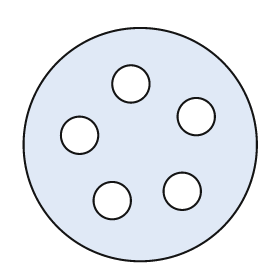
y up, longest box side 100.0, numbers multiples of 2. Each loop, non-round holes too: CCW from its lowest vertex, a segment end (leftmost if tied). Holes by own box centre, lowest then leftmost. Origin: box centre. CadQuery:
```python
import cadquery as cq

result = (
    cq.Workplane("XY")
    .moveTo(0.0, 0.0)
    .circle(50.0)
    .moveTo(-12.0, -24.0)
    .circle(8.0)
    .moveTo(18.0, -20.0)
    .circle(8.0)
    .moveTo(-26.0, 4.0)
    .circle(8.0)
    .moveTo(24.0, 12.0)
    .circle(8.0)
    .moveTo(-4.0, 26.0)
    .circle(8.0)
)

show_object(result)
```